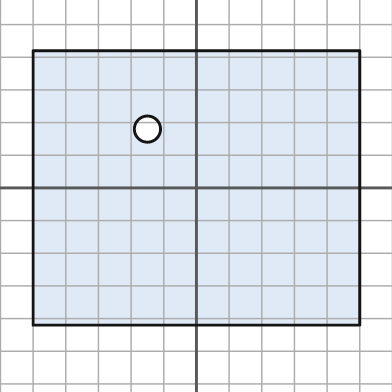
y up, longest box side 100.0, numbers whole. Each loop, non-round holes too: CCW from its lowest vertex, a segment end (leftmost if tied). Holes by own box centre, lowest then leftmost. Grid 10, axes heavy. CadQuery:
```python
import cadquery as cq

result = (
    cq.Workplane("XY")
    .moveTo(-50.0, -42.0)
    .lineTo(50.0, -42.0)
    .lineTo(50.0, 42.0)
    .lineTo(-50.0, 42.0)
    .close()
    .moveTo(-15.0, 18.0)
    .circle(4.0)
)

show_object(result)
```